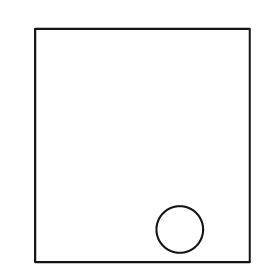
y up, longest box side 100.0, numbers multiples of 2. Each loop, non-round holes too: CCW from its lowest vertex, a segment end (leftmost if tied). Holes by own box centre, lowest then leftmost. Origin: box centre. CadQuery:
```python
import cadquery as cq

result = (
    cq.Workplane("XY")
    .moveTo(-46.0, -50.0)
    .lineTo(46.0, -50.0)
    .lineTo(46.0, 50.0)
    .lineTo(-46.0, 50.0)
    .close()
    .moveTo(16.0, -36.0)
    .circle(10.0)
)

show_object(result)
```